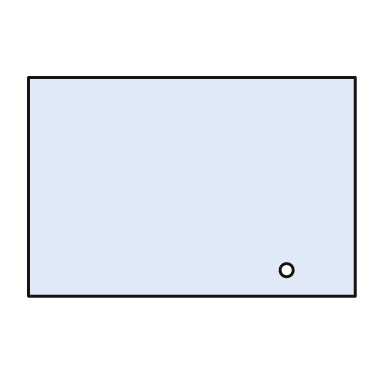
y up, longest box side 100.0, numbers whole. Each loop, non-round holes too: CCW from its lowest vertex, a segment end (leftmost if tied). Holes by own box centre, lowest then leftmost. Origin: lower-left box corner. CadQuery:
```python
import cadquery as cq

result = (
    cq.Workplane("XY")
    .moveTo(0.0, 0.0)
    .lineTo(100.0, 0.0)
    .lineTo(100.0, 67.0)
    .lineTo(0.0, 67.0)
    .close()
    .moveTo(79.0, 8.0)
    .circle(2.0)
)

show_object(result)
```